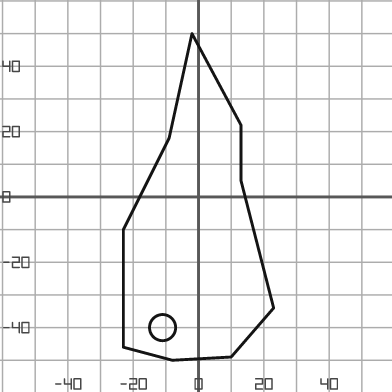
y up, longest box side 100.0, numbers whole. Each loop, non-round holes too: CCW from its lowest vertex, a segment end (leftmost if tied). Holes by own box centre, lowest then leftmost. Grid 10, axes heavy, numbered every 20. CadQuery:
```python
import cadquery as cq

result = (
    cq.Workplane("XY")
    .moveTo(-8.0, -50.0)
    .lineTo(10.0, -49.0)
    .lineTo(23.0, -34.0)
    .lineTo(13.0, 5.0)
    .lineTo(13.0, 22.0)
    .lineTo(-2.0, 50.0)
    .lineTo(-9.0, 18.0)
    .lineTo(-23.0, -10.0)
    .lineTo(-23.0, -46.0)
    .close()
    .moveTo(-11.0, -40.0)
    .circle(4.0)
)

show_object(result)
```